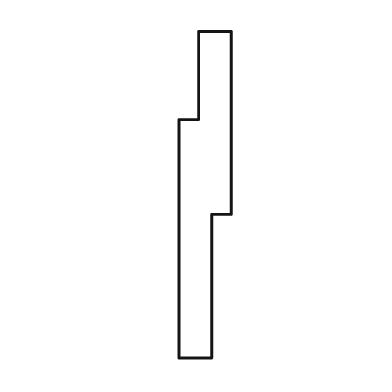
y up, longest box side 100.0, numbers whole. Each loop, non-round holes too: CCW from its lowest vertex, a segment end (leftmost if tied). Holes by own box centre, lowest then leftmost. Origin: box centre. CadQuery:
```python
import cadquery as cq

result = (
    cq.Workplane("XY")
    .moveTo(-8.0, -50.0)
    .lineTo(2.0, -50.0)
    .lineTo(2.0, -6.0)
    .lineTo(8.0, -6.0)
    .lineTo(8.0, 50.0)
    .lineTo(-2.0, 50.0)
    .lineTo(-2.0, 23.0)
    .lineTo(-8.0, 23.0)
    .close()
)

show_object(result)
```